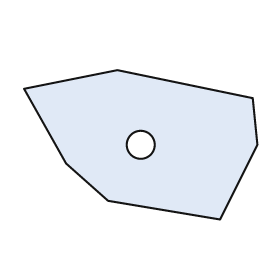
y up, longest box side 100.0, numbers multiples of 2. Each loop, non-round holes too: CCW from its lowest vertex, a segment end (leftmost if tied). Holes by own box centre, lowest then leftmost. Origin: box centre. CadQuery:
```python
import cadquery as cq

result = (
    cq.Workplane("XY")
    .moveTo(34.0, -32.0)
    .lineTo(50.0, 0.0)
    .lineTo(48.0, 20.0)
    .lineTo(-10.0, 32.0)
    .lineTo(-50.0, 24.0)
    .lineTo(-32.0, -8.0)
    .lineTo(-14.0, -24.0)
    .close()
    .moveTo(0.0, 0.0)
    .circle(6.0)
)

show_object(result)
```